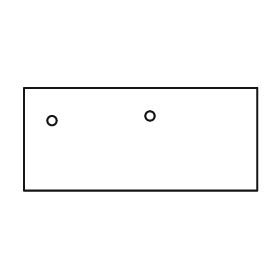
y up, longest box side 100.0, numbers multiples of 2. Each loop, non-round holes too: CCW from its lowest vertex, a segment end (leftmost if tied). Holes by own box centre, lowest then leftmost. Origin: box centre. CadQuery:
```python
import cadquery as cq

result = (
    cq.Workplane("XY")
    .moveTo(-50.0, -22.0)
    .lineTo(50.0, -22.0)
    .lineTo(50.0, 22.0)
    .lineTo(-50.0, 22.0)
    .close()
    .moveTo(-38.0, 8.0)
    .circle(2.0)
    .moveTo(4.0, 10.0)
    .circle(2.0)
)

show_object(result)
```